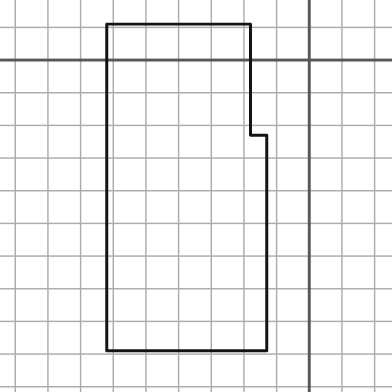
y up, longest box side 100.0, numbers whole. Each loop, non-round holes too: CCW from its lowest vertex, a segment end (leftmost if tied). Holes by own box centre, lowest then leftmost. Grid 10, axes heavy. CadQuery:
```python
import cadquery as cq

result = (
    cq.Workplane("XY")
    .moveTo(-62.0, -89.0)
    .lineTo(-13.0, -89.0)
    .lineTo(-13.0, -23.0)
    .lineTo(-18.0, -23.0)
    .lineTo(-18.0, 11.0)
    .lineTo(-62.0, 11.0)
    .close()
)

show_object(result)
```